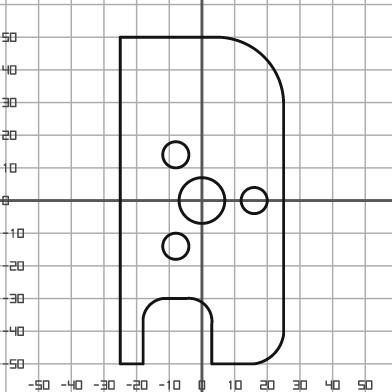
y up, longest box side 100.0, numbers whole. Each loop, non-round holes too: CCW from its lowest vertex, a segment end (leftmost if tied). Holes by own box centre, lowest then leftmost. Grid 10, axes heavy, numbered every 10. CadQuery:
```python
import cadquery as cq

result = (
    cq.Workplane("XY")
    .moveTo(-25.0, -50.0)
    .lineTo(-18.0, -50.0)
    .lineTo(-18.0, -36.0)
    .threePointArc((-16.0, -32.0), (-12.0, -30.0))
    .lineTo(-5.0, -30.0)
    .threePointArc((1.0, -32.0), (3.0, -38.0))
    .lineTo(3.0, -50.0)
    .lineTo(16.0, -50.0)
    .threePointArc((22.0, -47.0), (25.0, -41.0))
    .lineTo(25.0, 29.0)
    .threePointArc((19.0, 44.0), (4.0, 50.0))
    .lineTo(-25.0, 50.0)
    .close()
    .moveTo(-8.0, -14.0)
    .circle(4.0)
    .moveTo(0.0, 0.0)
    .circle(7.0)
    .moveTo(16.0, 0.0)
    .circle(4.0)
    .moveTo(-8.0, 14.0)
    .circle(4.0)
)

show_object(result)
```